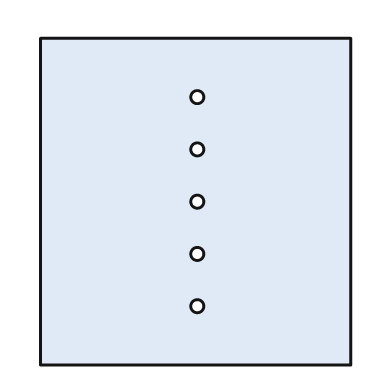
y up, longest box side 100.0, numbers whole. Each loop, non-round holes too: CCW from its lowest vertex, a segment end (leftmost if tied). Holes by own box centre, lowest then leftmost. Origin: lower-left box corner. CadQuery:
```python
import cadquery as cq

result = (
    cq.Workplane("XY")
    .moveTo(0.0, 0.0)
    .lineTo(95.0, 0.0)
    .lineTo(95.0, 100.0)
    .lineTo(0.0, 100.0)
    .close()
    .moveTo(48.0, 18.0)
    .circle(2.0)
    .moveTo(48.0, 34.0)
    .circle(2.0)
    .moveTo(48.0, 50.0)
    .circle(2.0)
    .moveTo(48.0, 66.0)
    .circle(2.0)
    .moveTo(48.0, 82.0)
    .circle(2.0)
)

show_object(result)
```